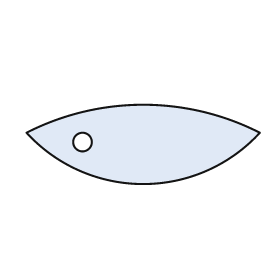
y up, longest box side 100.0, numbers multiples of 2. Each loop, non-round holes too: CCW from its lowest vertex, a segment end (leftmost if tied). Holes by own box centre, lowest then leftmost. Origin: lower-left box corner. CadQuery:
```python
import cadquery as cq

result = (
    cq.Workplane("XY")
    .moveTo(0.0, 22.0)
    .threePointArc((50.0, 0.0), (100.0, 22.0))
    .threePointArc((50.0, 34.0), (0.0, 22.0))
    .close()
    .moveTo(24.0, 18.0)
    .circle(4.0)
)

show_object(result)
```